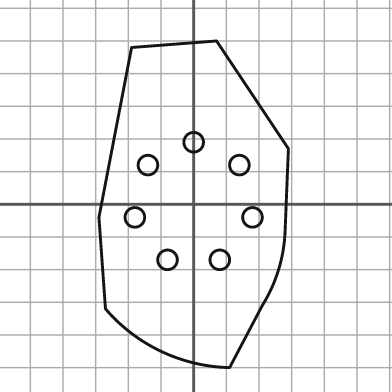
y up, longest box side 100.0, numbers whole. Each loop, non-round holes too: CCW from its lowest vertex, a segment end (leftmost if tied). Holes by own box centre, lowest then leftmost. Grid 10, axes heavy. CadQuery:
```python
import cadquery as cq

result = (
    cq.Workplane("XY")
    .moveTo(11.0, -50.0)
    .lineTo(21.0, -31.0)
    .threePointArc((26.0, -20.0), (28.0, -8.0))
    .lineTo(29.0, 17.0)
    .lineTo(7.0, 50.0)
    .lineTo(-19.0, 48.0)
    .lineTo(-29.0, -4.0)
    .lineTo(-27.0, -32.0)
    .threePointArc((-10.0, -45.0), (11.0, -50.0))
    .close()
    .moveTo(-8.0, -17.0)
    .circle(3.0)
    .moveTo(8.0, -17.0)
    .circle(3.0)
    .moveTo(-18.0, -4.0)
    .circle(3.0)
    .moveTo(18.0, -4.0)
    .circle(3.0)
    .moveTo(-14.0, 12.0)
    .circle(3.0)
    .moveTo(14.0, 12.0)
    .circle(3.0)
    .moveTo(0.0, 19.0)
    .circle(3.0)
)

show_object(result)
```